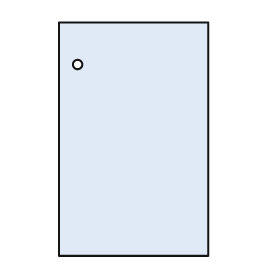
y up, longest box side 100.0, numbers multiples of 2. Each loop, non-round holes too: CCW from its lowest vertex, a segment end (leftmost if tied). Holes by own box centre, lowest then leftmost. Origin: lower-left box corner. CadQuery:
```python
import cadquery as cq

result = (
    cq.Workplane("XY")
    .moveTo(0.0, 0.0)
    .lineTo(64.0, 0.0)
    .lineTo(64.0, 100.0)
    .lineTo(0.0, 100.0)
    .close()
    .moveTo(8.0, 82.0)
    .circle(2.0)
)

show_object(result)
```